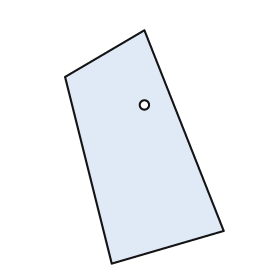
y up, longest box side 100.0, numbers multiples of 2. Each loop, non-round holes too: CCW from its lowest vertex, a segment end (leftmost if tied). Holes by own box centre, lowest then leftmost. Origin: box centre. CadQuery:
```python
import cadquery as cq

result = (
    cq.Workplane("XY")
    .moveTo(-14.0, -50.0)
    .lineTo(34.0, -36.0)
    .lineTo(0.0, 50.0)
    .lineTo(-34.0, 30.0)
    .close()
    .moveTo(0.0, 18.0)
    .circle(2.0)
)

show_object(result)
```